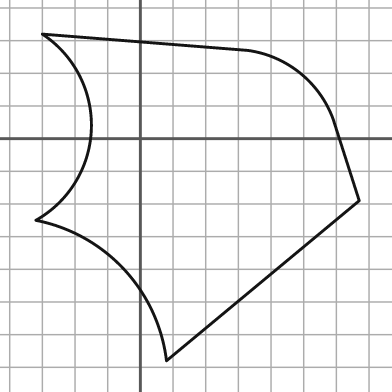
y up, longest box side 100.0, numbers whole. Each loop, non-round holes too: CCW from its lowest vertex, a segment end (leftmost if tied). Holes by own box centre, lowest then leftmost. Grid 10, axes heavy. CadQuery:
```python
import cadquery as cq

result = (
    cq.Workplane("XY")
    .moveTo(8.0, -68.0)
    .lineTo(67.0, -19.0)
    .lineTo(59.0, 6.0)
    .threePointArc((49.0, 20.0), (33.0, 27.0))
    .lineTo(-30.0, 32.0)
    .threePointArc((-15.0, 3.0), (-32.0, -25.0))
    .threePointArc((-5.0, -40.0), (8.0, -68.0))
    .close()
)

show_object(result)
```